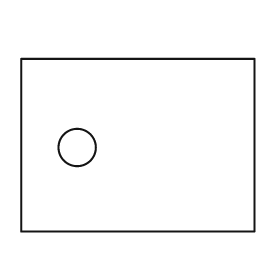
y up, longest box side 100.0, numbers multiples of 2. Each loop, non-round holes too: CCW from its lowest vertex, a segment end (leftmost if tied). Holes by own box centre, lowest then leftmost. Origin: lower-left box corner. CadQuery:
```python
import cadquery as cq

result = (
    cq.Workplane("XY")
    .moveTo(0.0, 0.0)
    .lineTo(100.0, 0.0)
    .lineTo(100.0, 74.0)
    .lineTo(0.0, 74.0)
    .close()
    .moveTo(24.0, 36.0)
    .circle(8.0)
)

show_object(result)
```